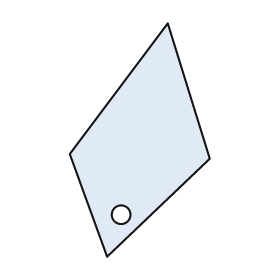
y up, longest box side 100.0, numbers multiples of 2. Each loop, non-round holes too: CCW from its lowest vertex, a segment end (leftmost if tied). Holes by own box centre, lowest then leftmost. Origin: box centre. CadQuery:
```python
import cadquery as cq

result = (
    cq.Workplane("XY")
    .moveTo(-14.0, -50.0)
    .lineTo(30.0, -8.0)
    .lineTo(12.0, 50.0)
    .lineTo(-30.0, -6.0)
    .close()
    .moveTo(-8.0, -32.0)
    .circle(4.0)
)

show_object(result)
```